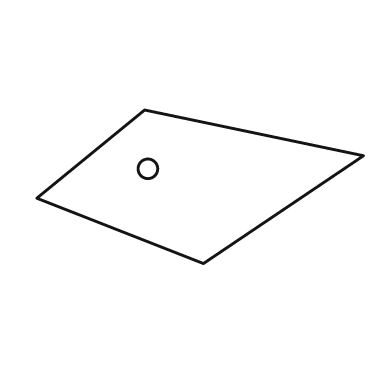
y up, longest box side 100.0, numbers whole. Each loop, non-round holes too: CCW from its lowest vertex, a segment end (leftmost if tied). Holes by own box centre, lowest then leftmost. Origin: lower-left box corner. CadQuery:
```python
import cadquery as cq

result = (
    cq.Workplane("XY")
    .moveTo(51.0, 0.0)
    .lineTo(100.0, 33.0)
    .lineTo(33.0, 47.0)
    .lineTo(0.0, 20.0)
    .close()
    .moveTo(34.0, 29.0)
    .circle(3.0)
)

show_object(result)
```